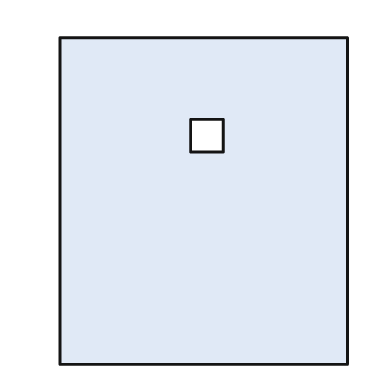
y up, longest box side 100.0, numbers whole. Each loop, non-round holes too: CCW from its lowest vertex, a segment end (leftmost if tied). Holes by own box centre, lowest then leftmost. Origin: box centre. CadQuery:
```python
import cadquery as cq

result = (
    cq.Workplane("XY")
    .moveTo(-44.0, -50.0)
    .lineTo(44.0, -50.0)
    .lineTo(44.0, 50.0)
    .lineTo(-44.0, 50.0)
    .close()
    .moveTo(-4.0, 15.0)
    .lineTo(6.0, 15.0)
    .lineTo(6.0, 25.0)
    .lineTo(-4.0, 25.0)
    .close()
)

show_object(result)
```